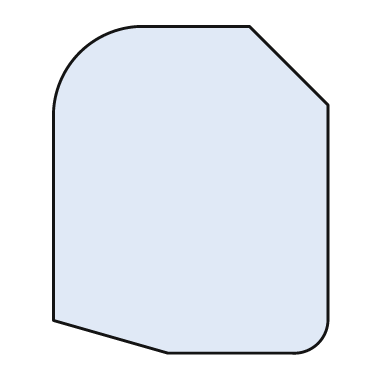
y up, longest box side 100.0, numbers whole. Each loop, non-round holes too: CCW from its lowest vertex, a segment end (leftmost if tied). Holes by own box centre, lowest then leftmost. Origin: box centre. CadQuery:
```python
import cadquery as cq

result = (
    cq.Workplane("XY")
    .moveTo(-7.0, -50.0)
    .lineTo(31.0, -50.0)
    .threePointArc((39.0, -47.0), (42.0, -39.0))
    .lineTo(42.0, 26.0)
    .lineTo(18.0, 50.0)
    .lineTo(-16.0, 50.0)
    .threePointArc((-34.0, 42.0), (-42.0, 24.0))
    .lineTo(-42.0, -40.0)
    .close()
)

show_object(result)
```